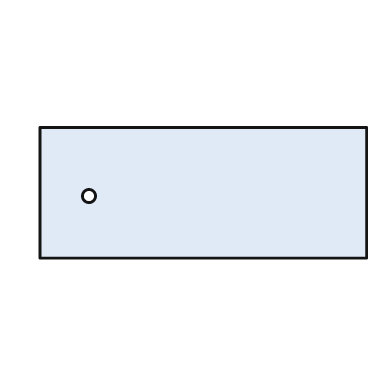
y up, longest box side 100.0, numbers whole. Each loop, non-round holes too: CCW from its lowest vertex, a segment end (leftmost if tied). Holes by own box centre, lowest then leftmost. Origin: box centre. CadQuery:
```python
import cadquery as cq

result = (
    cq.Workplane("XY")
    .moveTo(-50.0, -20.0)
    .lineTo(50.0, -20.0)
    .lineTo(50.0, 20.0)
    .lineTo(-50.0, 20.0)
    .close()
    .moveTo(-35.0, -1.0)
    .circle(2.0)
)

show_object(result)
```